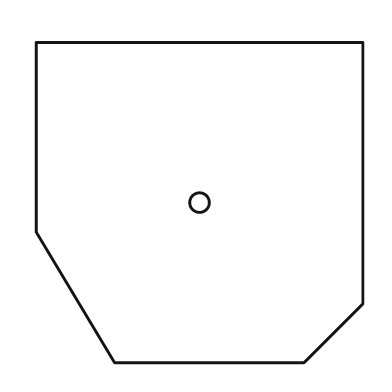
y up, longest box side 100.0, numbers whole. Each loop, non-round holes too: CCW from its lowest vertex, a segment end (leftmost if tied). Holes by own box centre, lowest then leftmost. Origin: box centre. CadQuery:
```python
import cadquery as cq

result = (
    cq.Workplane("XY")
    .moveTo(-26.0, -49.0)
    .lineTo(32.0, -49.0)
    .lineTo(50.0, -31.0)
    .lineTo(50.0, 49.0)
    .lineTo(-50.0, 49.0)
    .lineTo(-50.0, -9.0)
    .close()
    .moveTo(0.0, 0.0)
    .circle(3.0)
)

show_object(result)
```